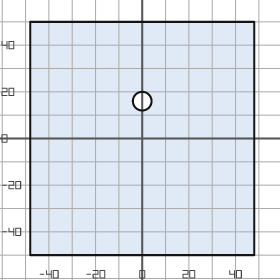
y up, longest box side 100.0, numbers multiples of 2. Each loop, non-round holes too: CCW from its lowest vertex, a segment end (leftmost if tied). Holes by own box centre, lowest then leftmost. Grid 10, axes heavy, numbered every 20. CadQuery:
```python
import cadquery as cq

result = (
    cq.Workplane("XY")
    .moveTo(-48.0, -50.0)
    .lineTo(48.0, -50.0)
    .lineTo(48.0, 50.0)
    .lineTo(-48.0, 50.0)
    .close()
    .moveTo(0.0, 16.0)
    .circle(4.0)
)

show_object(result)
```